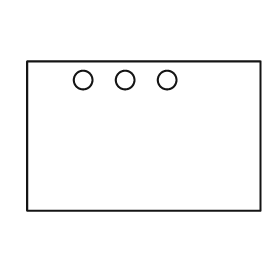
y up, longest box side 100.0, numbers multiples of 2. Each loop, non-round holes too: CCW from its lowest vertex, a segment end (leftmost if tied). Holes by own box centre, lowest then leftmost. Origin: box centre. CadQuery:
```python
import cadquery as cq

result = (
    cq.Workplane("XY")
    .moveTo(-50.0, -32.0)
    .lineTo(50.0, -32.0)
    .lineTo(50.0, 32.0)
    .lineTo(-50.0, 32.0)
    .close()
    .moveTo(-26.0, 24.0)
    .circle(4.0)
    .moveTo(-8.0, 24.0)
    .circle(4.0)
    .moveTo(10.0, 24.0)
    .circle(4.0)
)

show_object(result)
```